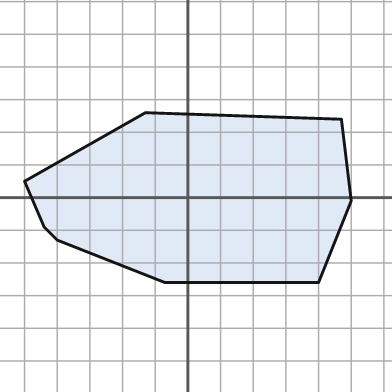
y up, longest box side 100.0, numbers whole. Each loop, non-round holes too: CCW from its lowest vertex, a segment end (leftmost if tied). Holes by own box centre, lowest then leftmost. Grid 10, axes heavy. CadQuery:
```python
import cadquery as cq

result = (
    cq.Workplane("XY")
    .moveTo(-7.0, -26.0)
    .lineTo(40.0, -26.0)
    .lineTo(50.0, -1.0)
    .lineTo(47.0, 24.0)
    .lineTo(-13.0, 26.0)
    .lineTo(-50.0, 5.0)
    .lineTo(-44.0, -9.0)
    .lineTo(-40.0, -13.0)
    .close()
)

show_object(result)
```